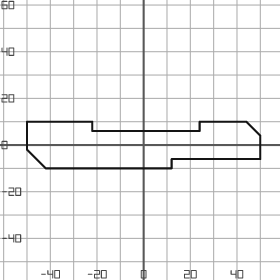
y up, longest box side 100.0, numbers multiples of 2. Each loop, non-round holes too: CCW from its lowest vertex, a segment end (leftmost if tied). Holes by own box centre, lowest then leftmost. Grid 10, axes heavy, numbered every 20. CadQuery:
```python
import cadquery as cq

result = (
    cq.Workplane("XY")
    .moveTo(-42.0, -10.0)
    .lineTo(12.0, -10.0)
    .lineTo(12.0, -6.0)
    .lineTo(50.0, -6.0)
    .lineTo(50.0, 4.0)
    .lineTo(44.0, 10.0)
    .lineTo(24.0, 10.0)
    .lineTo(24.0, 6.0)
    .lineTo(-22.0, 6.0)
    .lineTo(-22.0, 10.0)
    .lineTo(-50.0, 10.0)
    .lineTo(-50.0, -2.0)
    .close()
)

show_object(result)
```